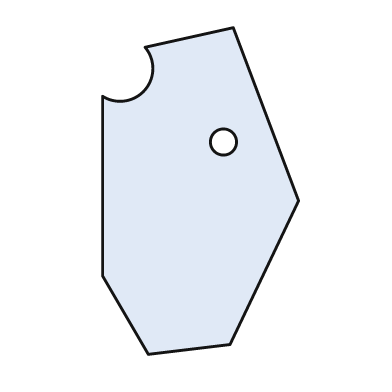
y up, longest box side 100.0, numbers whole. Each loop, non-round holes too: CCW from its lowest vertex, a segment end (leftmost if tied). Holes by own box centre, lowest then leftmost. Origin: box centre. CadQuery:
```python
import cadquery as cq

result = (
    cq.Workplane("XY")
    .moveTo(-16.0, -50.0)
    .lineTo(9.0, -47.0)
    .lineTo(30.0, -3.0)
    .lineTo(10.0, 50.0)
    .lineTo(-17.0, 44.0)
    .threePointArc((-17.0, 31.0), (-30.0, 29.0))
    .lineTo(-30.0, -26.0)
    .close()
    .moveTo(7.0, 15.0)
    .circle(4.0)
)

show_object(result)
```